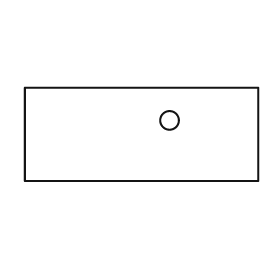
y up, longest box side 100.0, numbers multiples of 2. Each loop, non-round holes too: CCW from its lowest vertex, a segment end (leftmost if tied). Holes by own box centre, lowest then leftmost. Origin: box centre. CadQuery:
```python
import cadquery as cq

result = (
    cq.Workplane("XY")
    .moveTo(-50.0, -20.0)
    .lineTo(50.0, -20.0)
    .lineTo(50.0, 20.0)
    .lineTo(-50.0, 20.0)
    .close()
    .moveTo(12.0, 6.0)
    .circle(4.0)
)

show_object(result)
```